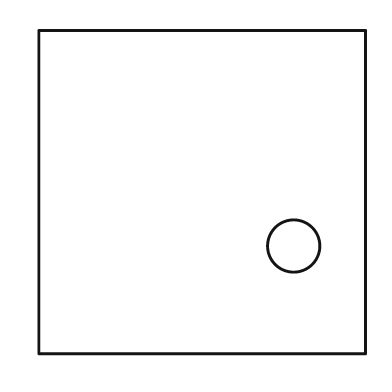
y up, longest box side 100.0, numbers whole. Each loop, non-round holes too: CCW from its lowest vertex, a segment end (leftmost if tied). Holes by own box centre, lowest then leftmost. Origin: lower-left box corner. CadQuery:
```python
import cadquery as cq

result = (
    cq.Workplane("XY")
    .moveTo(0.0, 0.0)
    .lineTo(100.0, 0.0)
    .lineTo(100.0, 99.0)
    .lineTo(0.0, 99.0)
    .close()
    .moveTo(78.0, 33.0)
    .circle(8.0)
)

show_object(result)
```